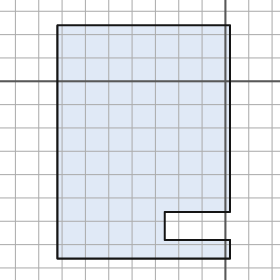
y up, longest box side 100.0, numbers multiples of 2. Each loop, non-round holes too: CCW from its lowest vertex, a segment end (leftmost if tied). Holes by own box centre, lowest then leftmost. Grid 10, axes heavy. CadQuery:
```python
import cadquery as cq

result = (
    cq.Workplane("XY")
    .moveTo(-72.0, -76.0)
    .lineTo(2.0, -76.0)
    .lineTo(2.0, -68.0)
    .lineTo(-26.0, -68.0)
    .lineTo(-26.0, -56.0)
    .lineTo(2.0, -56.0)
    .lineTo(2.0, 24.0)
    .lineTo(-72.0, 24.0)
    .close()
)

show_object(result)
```